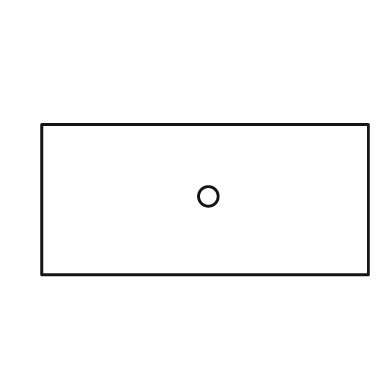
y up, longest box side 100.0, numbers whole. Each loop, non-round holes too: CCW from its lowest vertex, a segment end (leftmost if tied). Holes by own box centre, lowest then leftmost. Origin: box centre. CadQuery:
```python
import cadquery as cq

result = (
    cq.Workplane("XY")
    .moveTo(-50.0, -23.0)
    .lineTo(50.0, -23.0)
    .lineTo(50.0, 23.0)
    .lineTo(-50.0, 23.0)
    .close()
    .moveTo(1.0, 1.0)
    .circle(3.0)
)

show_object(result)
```